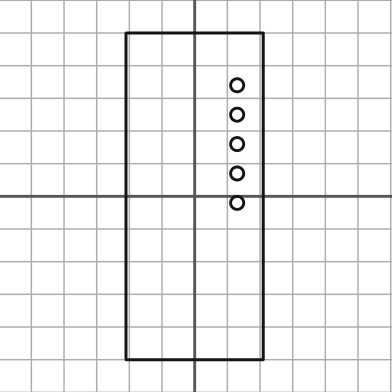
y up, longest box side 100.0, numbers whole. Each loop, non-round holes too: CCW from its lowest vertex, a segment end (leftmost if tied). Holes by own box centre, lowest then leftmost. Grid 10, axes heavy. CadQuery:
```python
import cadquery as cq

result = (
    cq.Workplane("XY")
    .moveTo(-21.0, -50.0)
    .lineTo(21.0, -50.0)
    .lineTo(21.0, 50.0)
    .lineTo(-21.0, 50.0)
    .close()
    .moveTo(13.0, -2.0)
    .circle(2.0)
    .moveTo(13.0, 7.0)
    .circle(2.0)
    .moveTo(13.0, 16.0)
    .circle(2.0)
    .moveTo(13.0, 25.0)
    .circle(2.0)
    .moveTo(13.0, 34.0)
    .circle(2.0)
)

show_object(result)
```